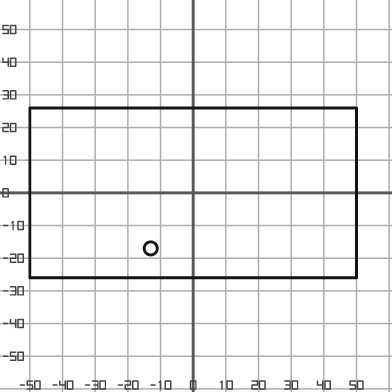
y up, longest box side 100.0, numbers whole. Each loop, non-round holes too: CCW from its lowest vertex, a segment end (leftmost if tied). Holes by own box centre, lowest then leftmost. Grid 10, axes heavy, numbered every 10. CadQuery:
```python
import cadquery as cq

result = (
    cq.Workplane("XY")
    .moveTo(-50.0, -26.0)
    .lineTo(50.0, -26.0)
    .lineTo(50.0, 26.0)
    .lineTo(-50.0, 26.0)
    .close()
    .moveTo(-13.0, -17.0)
    .circle(2.0)
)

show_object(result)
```